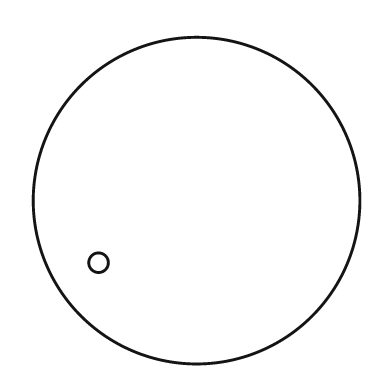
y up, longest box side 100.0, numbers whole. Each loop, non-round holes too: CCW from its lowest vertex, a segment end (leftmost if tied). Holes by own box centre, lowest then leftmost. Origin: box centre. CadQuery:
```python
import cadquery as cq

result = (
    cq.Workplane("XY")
    .moveTo(0.0, 0.0)
    .circle(50.0)
    .moveTo(-30.0, -19.0)
    .circle(3.0)
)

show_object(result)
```